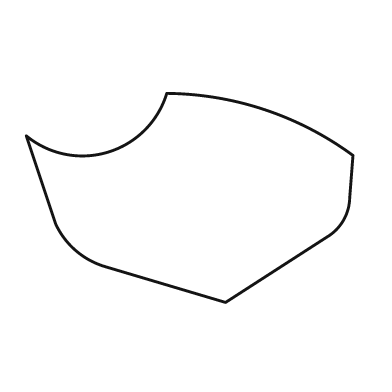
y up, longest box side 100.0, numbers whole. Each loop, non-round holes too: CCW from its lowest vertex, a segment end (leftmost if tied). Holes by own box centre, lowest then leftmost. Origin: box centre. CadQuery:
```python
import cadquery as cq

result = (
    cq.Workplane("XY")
    .moveTo(11.0, -32.0)
    .lineTo(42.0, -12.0)
    .threePointArc((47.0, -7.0), (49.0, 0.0))
    .lineTo(50.0, 13.0)
    .threePointArc((23.0, 27.0), (-7.0, 32.0))
    .threePointArc((-25.0, 14.0), (-50.0, 19.0))
    .lineTo(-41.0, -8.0)
    .threePointArc((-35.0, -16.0), (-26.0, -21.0))
    .close()
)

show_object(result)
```